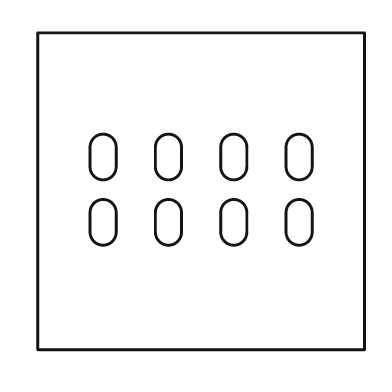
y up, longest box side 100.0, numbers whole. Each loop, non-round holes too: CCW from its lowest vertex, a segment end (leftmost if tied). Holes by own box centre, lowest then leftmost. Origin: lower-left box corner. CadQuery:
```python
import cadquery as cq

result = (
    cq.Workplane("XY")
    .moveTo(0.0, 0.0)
    .lineTo(100.0, 0.0)
    .lineTo(100.0, 97.0)
    .lineTo(0.0, 97.0)
    .close()
    .moveTo(16.0, 36.0)
    .threePointArc((20.0, 32.0), (24.0, 36.0))
    .lineTo(24.0, 42.0)
    .threePointArc((20.0, 46.0), (16.0, 42.0))
    .close()
    .moveTo(36.0, 36.0)
    .threePointArc((40.0, 32.0), (44.0, 36.0))
    .lineTo(44.0, 42.0)
    .threePointArc((40.0, 46.0), (36.0, 42.0))
    .close()
    .moveTo(56.0, 36.0)
    .threePointArc((60.0, 32.0), (64.0, 36.0))
    .lineTo(64.0, 42.0)
    .threePointArc((60.0, 46.0), (56.0, 42.0))
    .close()
    .moveTo(76.0, 36.0)
    .threePointArc((80.0, 32.0), (84.0, 36.0))
    .lineTo(84.0, 42.0)
    .threePointArc((80.0, 46.0), (76.0, 42.0))
    .close()
    .moveTo(16.0, 56.0)
    .threePointArc((20.0, 52.0), (24.0, 56.0))
    .lineTo(24.0, 62.0)
    .threePointArc((20.0, 66.0), (16.0, 62.0))
    .close()
    .moveTo(36.0, 56.0)
    .threePointArc((40.0, 52.0), (44.0, 56.0))
    .lineTo(44.0, 62.0)
    .threePointArc((40.0, 66.0), (36.0, 62.0))
    .close()
    .moveTo(56.0, 56.0)
    .threePointArc((60.0, 52.0), (64.0, 56.0))
    .lineTo(64.0, 62.0)
    .threePointArc((60.0, 66.0), (56.0, 62.0))
    .close()
    .moveTo(76.0, 56.0)
    .threePointArc((80.0, 52.0), (84.0, 56.0))
    .lineTo(84.0, 62.0)
    .threePointArc((80.0, 66.0), (76.0, 62.0))
    .close()
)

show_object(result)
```